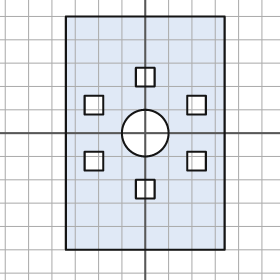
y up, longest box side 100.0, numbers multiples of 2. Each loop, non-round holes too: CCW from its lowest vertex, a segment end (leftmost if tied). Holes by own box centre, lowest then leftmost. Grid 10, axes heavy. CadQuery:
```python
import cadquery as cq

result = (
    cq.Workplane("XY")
    .moveTo(-34.0, -50.0)
    .lineTo(34.0, -50.0)
    .lineTo(34.0, 50.0)
    .lineTo(-34.0, 50.0)
    .close()
    .moveTo(-4.0, -28.0)
    .lineTo(4.0, -28.0)
    .lineTo(4.0, -20.0)
    .lineTo(-4.0, -20.0)
    .close()
    .moveTo(-26.0, -16.0)
    .lineTo(-18.0, -16.0)
    .lineTo(-18.0, -8.0)
    .lineTo(-26.0, -8.0)
    .close()
    .moveTo(18.0, -16.0)
    .lineTo(26.0, -16.0)
    .lineTo(26.0, -8.0)
    .lineTo(18.0, -8.0)
    .close()
    .moveTo(0.0, 0.0)
    .circle(10.0)
    .moveTo(-26.0, 8.0)
    .lineTo(-18.0, 8.0)
    .lineTo(-18.0, 16.0)
    .lineTo(-26.0, 16.0)
    .close()
    .moveTo(18.0, 8.0)
    .lineTo(26.0, 8.0)
    .lineTo(26.0, 16.0)
    .lineTo(18.0, 16.0)
    .close()
    .moveTo(-4.0, 20.0)
    .lineTo(4.0, 20.0)
    .lineTo(4.0, 28.0)
    .lineTo(-4.0, 28.0)
    .close()
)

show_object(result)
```